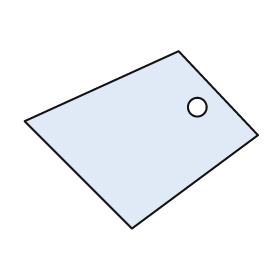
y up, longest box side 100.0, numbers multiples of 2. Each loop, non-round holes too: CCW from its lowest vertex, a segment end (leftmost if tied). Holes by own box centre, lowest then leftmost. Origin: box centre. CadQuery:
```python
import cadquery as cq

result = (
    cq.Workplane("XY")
    .moveTo(-4.0, -38.0)
    .lineTo(50.0, 2.0)
    .lineTo(16.0, 38.0)
    .lineTo(-50.0, 8.0)
    .close()
    .moveTo(24.0, 14.0)
    .circle(4.0)
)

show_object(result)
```